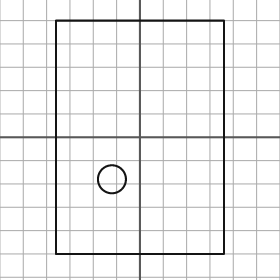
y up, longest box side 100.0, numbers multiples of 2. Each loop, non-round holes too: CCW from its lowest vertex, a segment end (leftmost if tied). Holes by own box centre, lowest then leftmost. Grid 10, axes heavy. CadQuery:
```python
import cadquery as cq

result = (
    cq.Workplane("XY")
    .moveTo(-36.0, -50.0)
    .lineTo(36.0, -50.0)
    .lineTo(36.0, 50.0)
    .lineTo(-36.0, 50.0)
    .close()
    .moveTo(-12.0, -18.0)
    .circle(6.0)
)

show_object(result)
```